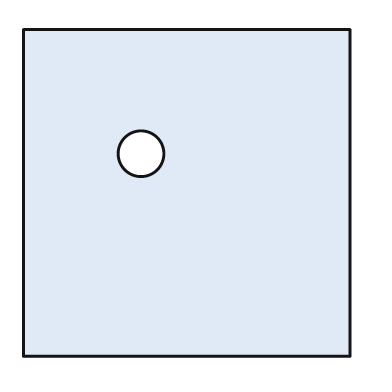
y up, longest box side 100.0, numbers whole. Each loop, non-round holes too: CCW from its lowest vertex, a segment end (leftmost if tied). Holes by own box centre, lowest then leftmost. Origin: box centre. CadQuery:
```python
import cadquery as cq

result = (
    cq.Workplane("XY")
    .moveTo(-50.0, -50.0)
    .lineTo(50.0, -50.0)
    .lineTo(50.0, 50.0)
    .lineTo(-50.0, 50.0)
    .close()
    .moveTo(-14.0, 12.0)
    .circle(7.0)
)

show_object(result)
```